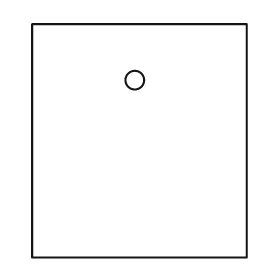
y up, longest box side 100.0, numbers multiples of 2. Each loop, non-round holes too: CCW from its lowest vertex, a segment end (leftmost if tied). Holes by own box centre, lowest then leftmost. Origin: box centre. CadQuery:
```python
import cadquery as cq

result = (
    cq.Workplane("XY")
    .moveTo(-46.0, -50.0)
    .lineTo(46.0, -50.0)
    .lineTo(46.0, 50.0)
    .lineTo(-46.0, 50.0)
    .close()
    .moveTo(-2.0, 26.0)
    .circle(4.0)
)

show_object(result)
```